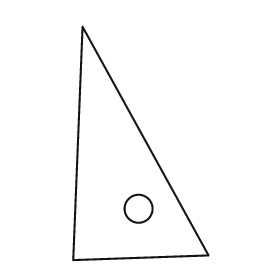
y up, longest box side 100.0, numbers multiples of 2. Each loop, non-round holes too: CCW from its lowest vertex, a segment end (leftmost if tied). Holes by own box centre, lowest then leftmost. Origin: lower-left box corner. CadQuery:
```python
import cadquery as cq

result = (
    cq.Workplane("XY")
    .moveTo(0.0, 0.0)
    .lineTo(58.0, 2.0)
    .lineTo(4.0, 100.0)
    .close()
    .moveTo(28.0, 22.0)
    .circle(6.0)
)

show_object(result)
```